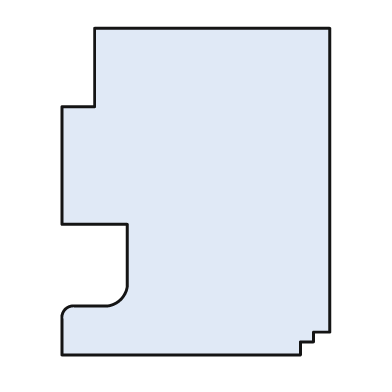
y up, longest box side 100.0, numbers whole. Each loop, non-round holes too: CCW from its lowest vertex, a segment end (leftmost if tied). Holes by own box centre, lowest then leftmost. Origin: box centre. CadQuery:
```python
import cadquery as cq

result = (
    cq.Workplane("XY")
    .moveTo(-41.0, -50.0)
    .lineTo(32.0, -50.0)
    .lineTo(32.0, -46.0)
    .lineTo(36.0, -46.0)
    .lineTo(36.0, -43.0)
    .lineTo(41.0, -43.0)
    .lineTo(41.0, 50.0)
    .lineTo(-31.0, 50.0)
    .lineTo(-31.0, 26.0)
    .lineTo(-41.0, 26.0)
    .lineTo(-41.0, -10.0)
    .lineTo(-21.0, -10.0)
    .lineTo(-21.0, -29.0)
    .threePointArc((-23.0, -33.0), (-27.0, -35.0))
    .lineTo(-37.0, -35.0)
    .threePointArc((-40.0, -36.0), (-41.0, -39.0))
    .close()
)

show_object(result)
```